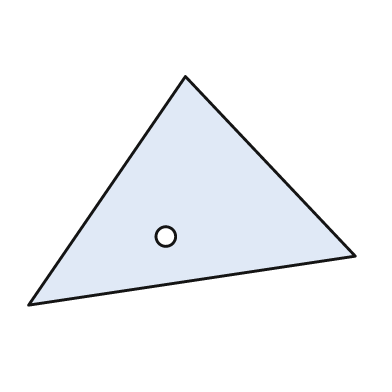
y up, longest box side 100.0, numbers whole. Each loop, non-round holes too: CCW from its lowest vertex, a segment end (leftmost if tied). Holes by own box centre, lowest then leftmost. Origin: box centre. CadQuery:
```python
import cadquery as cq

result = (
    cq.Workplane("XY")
    .moveTo(-50.0, -35.0)
    .lineTo(50.0, -20.0)
    .lineTo(-2.0, 35.0)
    .close()
    .moveTo(-8.0, -14.0)
    .circle(3.0)
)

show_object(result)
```